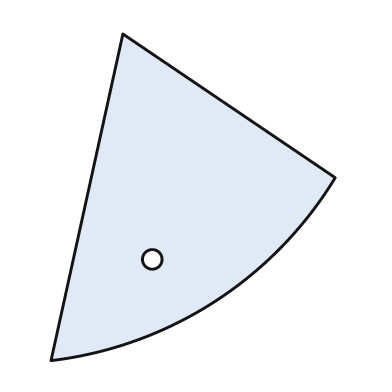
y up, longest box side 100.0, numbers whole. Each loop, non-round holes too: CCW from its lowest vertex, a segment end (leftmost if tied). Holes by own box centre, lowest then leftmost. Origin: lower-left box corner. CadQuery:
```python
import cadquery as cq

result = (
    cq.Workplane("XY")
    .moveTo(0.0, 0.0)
    .threePointArc((50.0, 18.0), (87.0, 56.0))
    .lineTo(22.0, 100.0)
    .close()
    .moveTo(31.0, 31.0)
    .circle(3.0)
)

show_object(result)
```